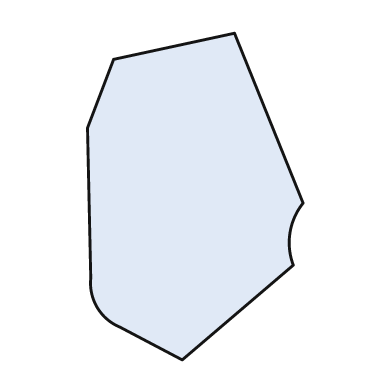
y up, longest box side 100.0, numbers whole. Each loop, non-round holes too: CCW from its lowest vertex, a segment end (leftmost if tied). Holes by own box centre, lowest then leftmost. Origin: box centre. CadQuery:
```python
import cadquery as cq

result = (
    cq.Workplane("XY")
    .moveTo(-4.0, -50.0)
    .lineTo(30.0, -21.0)
    .threePointArc((29.0, -11.0), (33.0, -2.0))
    .lineTo(12.0, 50.0)
    .lineTo(-25.0, 42.0)
    .lineTo(-33.0, 21.0)
    .lineTo(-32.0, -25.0)
    .threePointArc((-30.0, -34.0), (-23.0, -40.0))
    .close()
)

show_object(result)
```